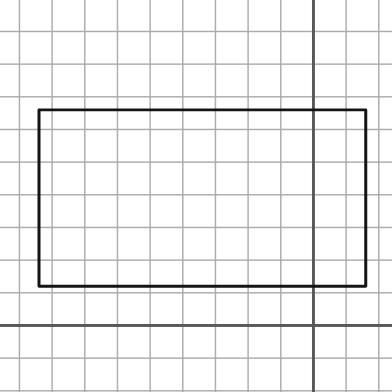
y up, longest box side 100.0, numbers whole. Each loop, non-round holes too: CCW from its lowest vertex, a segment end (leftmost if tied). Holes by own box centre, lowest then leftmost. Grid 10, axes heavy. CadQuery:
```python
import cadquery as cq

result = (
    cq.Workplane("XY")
    .moveTo(-84.0, 12.0)
    .lineTo(16.0, 12.0)
    .lineTo(16.0, 66.0)
    .lineTo(-84.0, 66.0)
    .close()
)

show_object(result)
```